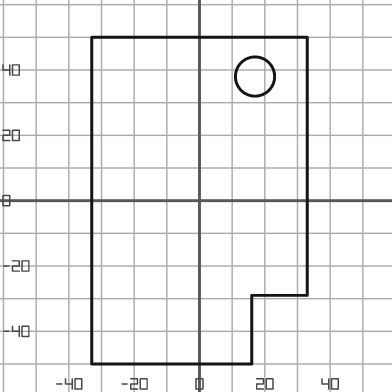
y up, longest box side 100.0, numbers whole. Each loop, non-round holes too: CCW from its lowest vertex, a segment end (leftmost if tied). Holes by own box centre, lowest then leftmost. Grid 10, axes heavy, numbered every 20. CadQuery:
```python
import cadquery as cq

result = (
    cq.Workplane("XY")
    .moveTo(-33.0, -50.0)
    .lineTo(16.0, -50.0)
    .lineTo(16.0, -29.0)
    .lineTo(33.0, -29.0)
    .lineTo(33.0, 50.0)
    .lineTo(-33.0, 50.0)
    .close()
    .moveTo(17.0, 38.0)
    .circle(6.0)
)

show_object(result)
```